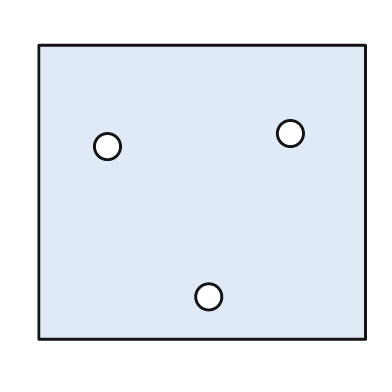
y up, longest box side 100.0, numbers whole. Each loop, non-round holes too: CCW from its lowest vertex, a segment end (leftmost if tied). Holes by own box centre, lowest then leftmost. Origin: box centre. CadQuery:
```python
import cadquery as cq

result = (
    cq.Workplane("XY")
    .moveTo(-50.0, -45.0)
    .lineTo(50.0, -45.0)
    .lineTo(50.0, 45.0)
    .lineTo(-50.0, 45.0)
    .close()
    .moveTo(2.0, -32.0)
    .circle(4.0)
    .moveTo(-29.0, 14.0)
    .circle(4.0)
    .moveTo(27.0, 18.0)
    .circle(4.0)
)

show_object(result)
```